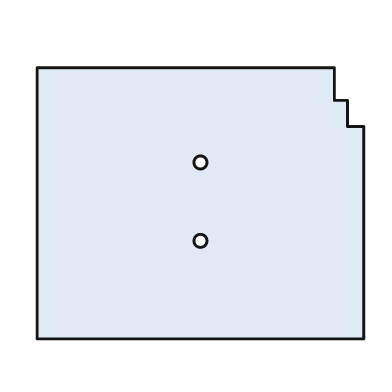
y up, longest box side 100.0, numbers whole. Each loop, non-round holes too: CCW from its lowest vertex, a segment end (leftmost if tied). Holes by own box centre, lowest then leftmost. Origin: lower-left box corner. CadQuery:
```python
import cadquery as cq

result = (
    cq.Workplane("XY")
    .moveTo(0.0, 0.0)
    .lineTo(100.0, 0.0)
    .lineTo(100.0, 65.0)
    .lineTo(95.0, 65.0)
    .lineTo(95.0, 73.0)
    .lineTo(91.0, 73.0)
    .lineTo(91.0, 83.0)
    .lineTo(0.0, 83.0)
    .close()
    .moveTo(50.0, 30.0)
    .circle(2.0)
    .moveTo(50.0, 54.0)
    .circle(2.0)
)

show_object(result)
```